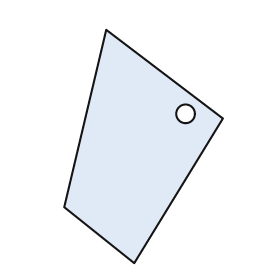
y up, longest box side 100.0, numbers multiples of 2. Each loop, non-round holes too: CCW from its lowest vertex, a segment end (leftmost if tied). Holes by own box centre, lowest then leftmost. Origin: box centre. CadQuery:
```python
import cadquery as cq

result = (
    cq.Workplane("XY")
    .moveTo(-4.0, -50.0)
    .lineTo(34.0, 12.0)
    .lineTo(-16.0, 50.0)
    .lineTo(-34.0, -26.0)
    .close()
    .moveTo(18.0, 14.0)
    .circle(4.0)
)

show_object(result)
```